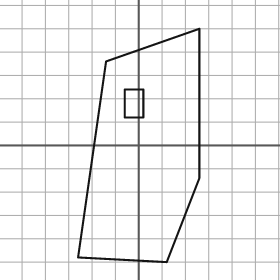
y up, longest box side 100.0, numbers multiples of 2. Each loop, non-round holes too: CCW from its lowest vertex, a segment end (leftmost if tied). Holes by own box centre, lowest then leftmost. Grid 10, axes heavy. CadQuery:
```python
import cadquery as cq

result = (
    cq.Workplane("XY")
    .moveTo(12.0, -50.0)
    .lineTo(26.0, -14.0)
    .lineTo(26.0, 50.0)
    .lineTo(-14.0, 36.0)
    .lineTo(-26.0, -48.0)
    .close()
    .moveTo(-6.0, 12.0)
    .lineTo(2.0, 12.0)
    .lineTo(2.0, 24.0)
    .lineTo(-6.0, 24.0)
    .close()
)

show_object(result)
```